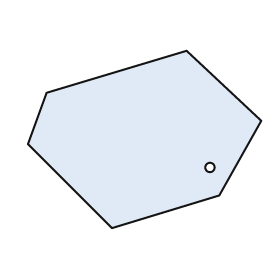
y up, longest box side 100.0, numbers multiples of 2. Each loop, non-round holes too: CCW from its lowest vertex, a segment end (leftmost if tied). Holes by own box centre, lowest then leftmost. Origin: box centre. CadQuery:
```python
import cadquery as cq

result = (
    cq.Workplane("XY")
    .moveTo(-14.0, -38.0)
    .lineTo(32.0, -24.0)
    .lineTo(50.0, 8.0)
    .lineTo(18.0, 38.0)
    .lineTo(-42.0, 20.0)
    .lineTo(-50.0, -2.0)
    .close()
    .moveTo(28.0, -12.0)
    .circle(2.0)
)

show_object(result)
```